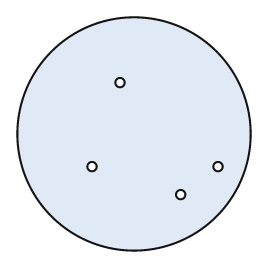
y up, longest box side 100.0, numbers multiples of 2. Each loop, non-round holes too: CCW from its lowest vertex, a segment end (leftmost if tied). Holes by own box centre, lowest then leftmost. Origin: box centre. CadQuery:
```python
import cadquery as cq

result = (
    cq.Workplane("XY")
    .moveTo(0.0, 0.0)
    .circle(50.0)
    .moveTo(20.0, -26.0)
    .circle(2.0)
    .moveTo(-18.0, -14.0)
    .circle(2.0)
    .moveTo(36.0, -14.0)
    .circle(2.0)
    .moveTo(-6.0, 22.0)
    .circle(2.0)
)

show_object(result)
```